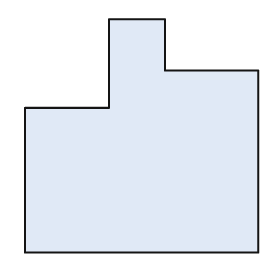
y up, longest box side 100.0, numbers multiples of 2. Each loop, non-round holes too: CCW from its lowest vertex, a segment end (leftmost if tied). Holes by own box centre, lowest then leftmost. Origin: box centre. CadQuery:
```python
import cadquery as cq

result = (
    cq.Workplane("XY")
    .moveTo(-50.0, -50.0)
    .lineTo(50.0, -50.0)
    .lineTo(50.0, 28.0)
    .lineTo(10.0, 28.0)
    .lineTo(10.0, 50.0)
    .lineTo(-14.0, 50.0)
    .lineTo(-14.0, 12.0)
    .lineTo(-50.0, 12.0)
    .close()
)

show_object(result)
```